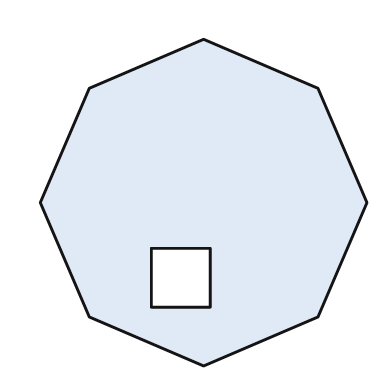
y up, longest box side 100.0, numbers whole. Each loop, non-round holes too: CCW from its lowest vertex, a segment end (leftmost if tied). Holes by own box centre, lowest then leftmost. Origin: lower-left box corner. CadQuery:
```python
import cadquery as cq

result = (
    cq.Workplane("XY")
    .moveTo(50.0, 0.0)
    .lineTo(85.0, 15.0)
    .lineTo(100.0, 50.0)
    .lineTo(85.0, 85.0)
    .lineTo(50.0, 100.0)
    .lineTo(15.0, 85.0)
    .lineTo(0.0, 50.0)
    .lineTo(15.0, 15.0)
    .close()
    .moveTo(34.0, 18.0)
    .lineTo(52.0, 18.0)
    .lineTo(52.0, 36.0)
    .lineTo(34.0, 36.0)
    .close()
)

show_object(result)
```